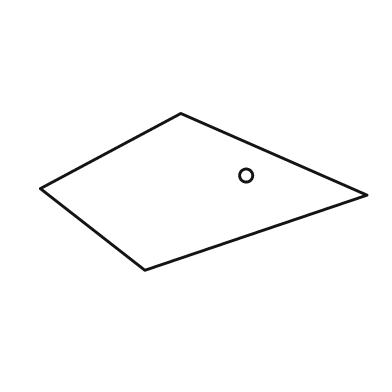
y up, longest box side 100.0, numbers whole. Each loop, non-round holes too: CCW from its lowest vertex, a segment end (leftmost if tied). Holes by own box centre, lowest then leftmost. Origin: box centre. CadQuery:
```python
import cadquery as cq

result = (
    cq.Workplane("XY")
    .moveTo(-18.0, -24.0)
    .lineTo(50.0, -1.0)
    .lineTo(-7.0, 24.0)
    .lineTo(-50.0, 1.0)
    .close()
    .moveTo(13.0, 5.0)
    .circle(2.0)
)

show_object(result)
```